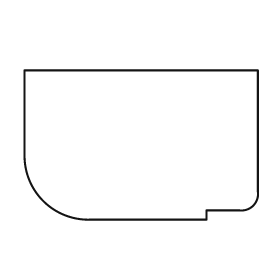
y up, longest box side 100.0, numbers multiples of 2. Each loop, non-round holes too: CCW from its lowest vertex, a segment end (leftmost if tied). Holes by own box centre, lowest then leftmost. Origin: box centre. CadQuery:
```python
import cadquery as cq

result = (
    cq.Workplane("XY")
    .moveTo(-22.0, -32.0)
    .lineTo(28.0, -32.0)
    .lineTo(28.0, -28.0)
    .lineTo(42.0, -28.0)
    .threePointArc((48.0, -26.0), (50.0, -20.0))
    .lineTo(50.0, 32.0)
    .lineTo(-50.0, 32.0)
    .lineTo(-50.0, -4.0)
    .threePointArc((-42.0, -24.0), (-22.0, -32.0))
    .close()
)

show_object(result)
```